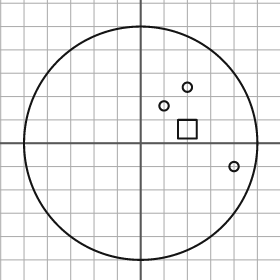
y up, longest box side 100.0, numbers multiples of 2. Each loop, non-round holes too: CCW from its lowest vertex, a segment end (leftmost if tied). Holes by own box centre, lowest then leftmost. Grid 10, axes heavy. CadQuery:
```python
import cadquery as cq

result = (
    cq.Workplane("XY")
    .moveTo(0.0, 0.0)
    .circle(50.0)
    .moveTo(40.0, -10.0)
    .circle(2.0)
    .moveTo(16.0, 2.0)
    .lineTo(24.0, 2.0)
    .lineTo(24.0, 10.0)
    .lineTo(16.0, 10.0)
    .close()
    .moveTo(10.0, 16.0)
    .circle(2.0)
    .moveTo(20.0, 24.0)
    .circle(2.0)
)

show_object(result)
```